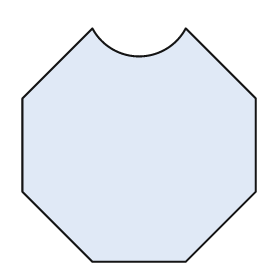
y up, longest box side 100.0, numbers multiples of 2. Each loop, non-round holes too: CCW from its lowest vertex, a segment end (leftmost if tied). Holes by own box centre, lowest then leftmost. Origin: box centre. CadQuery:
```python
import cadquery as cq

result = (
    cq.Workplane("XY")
    .moveTo(-20.0, -50.0)
    .lineTo(20.0, -50.0)
    .lineTo(50.0, -20.0)
    .lineTo(50.0, 20.0)
    .lineTo(20.0, 50.0)
    .threePointArc((0.0, 38.0), (-20.0, 50.0))
    .lineTo(-50.0, 20.0)
    .lineTo(-50.0, -20.0)
    .close()
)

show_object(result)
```